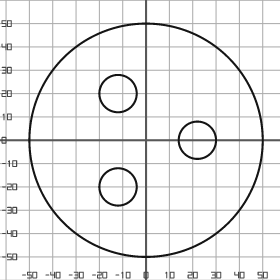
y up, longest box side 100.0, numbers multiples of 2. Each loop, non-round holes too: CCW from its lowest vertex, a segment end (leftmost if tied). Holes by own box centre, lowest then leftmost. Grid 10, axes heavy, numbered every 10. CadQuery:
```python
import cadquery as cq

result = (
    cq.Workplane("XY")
    .moveTo(0.0, 0.0)
    .circle(50.0)
    .moveTo(-12.0, -20.0)
    .circle(8.0)
    .moveTo(22.0, 0.0)
    .circle(8.0)
    .moveTo(-12.0, 20.0)
    .circle(8.0)
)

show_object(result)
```